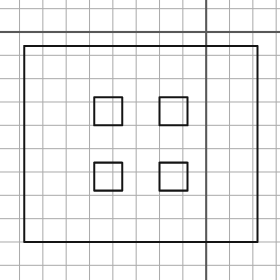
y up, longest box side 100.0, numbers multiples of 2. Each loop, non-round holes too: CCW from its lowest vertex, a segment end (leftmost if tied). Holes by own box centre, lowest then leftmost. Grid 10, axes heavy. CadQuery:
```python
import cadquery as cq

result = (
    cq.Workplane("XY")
    .moveTo(-78.0, -90.0)
    .lineTo(22.0, -90.0)
    .lineTo(22.0, -6.0)
    .lineTo(-78.0, -6.0)
    .close()
    .moveTo(-48.0, -68.0)
    .lineTo(-36.0, -68.0)
    .lineTo(-36.0, -56.0)
    .lineTo(-48.0, -56.0)
    .close()
    .moveTo(-20.0, -68.0)
    .lineTo(-8.0, -68.0)
    .lineTo(-8.0, -56.0)
    .lineTo(-20.0, -56.0)
    .close()
    .moveTo(-48.0, -40.0)
    .lineTo(-36.0, -40.0)
    .lineTo(-36.0, -28.0)
    .lineTo(-48.0, -28.0)
    .close()
    .moveTo(-20.0, -40.0)
    .lineTo(-8.0, -40.0)
    .lineTo(-8.0, -28.0)
    .lineTo(-20.0, -28.0)
    .close()
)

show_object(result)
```